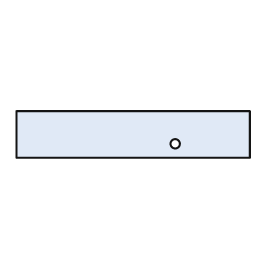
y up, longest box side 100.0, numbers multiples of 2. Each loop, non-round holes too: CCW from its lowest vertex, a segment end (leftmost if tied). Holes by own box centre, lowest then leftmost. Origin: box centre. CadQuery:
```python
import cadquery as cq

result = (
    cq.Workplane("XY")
    .moveTo(-50.0, -10.0)
    .lineTo(50.0, -10.0)
    .lineTo(50.0, 10.0)
    .lineTo(-50.0, 10.0)
    .close()
    .moveTo(18.0, -4.0)
    .circle(2.0)
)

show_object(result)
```